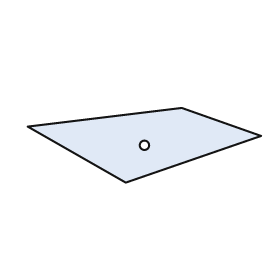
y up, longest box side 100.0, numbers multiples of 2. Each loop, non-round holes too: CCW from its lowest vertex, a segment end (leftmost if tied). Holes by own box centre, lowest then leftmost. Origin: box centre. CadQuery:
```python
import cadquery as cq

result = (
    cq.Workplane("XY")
    .moveTo(-8.0, -16.0)
    .lineTo(50.0, 4.0)
    .lineTo(16.0, 16.0)
    .lineTo(-50.0, 8.0)
    .close()
    .moveTo(0.0, 0.0)
    .circle(2.0)
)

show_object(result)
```